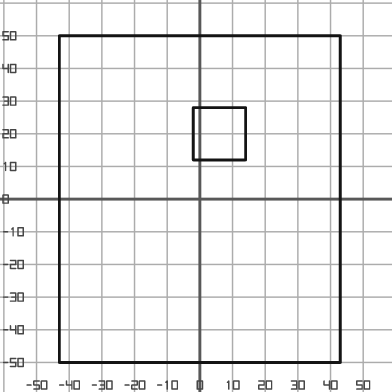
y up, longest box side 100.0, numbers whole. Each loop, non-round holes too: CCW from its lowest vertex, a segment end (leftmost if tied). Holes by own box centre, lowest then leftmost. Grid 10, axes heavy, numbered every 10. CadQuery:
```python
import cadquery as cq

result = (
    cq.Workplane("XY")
    .moveTo(-43.0, -50.0)
    .lineTo(43.0, -50.0)
    .lineTo(43.0, 50.0)
    .lineTo(-43.0, 50.0)
    .close()
    .moveTo(-2.0, 12.0)
    .lineTo(14.0, 12.0)
    .lineTo(14.0, 28.0)
    .lineTo(-2.0, 28.0)
    .close()
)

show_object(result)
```